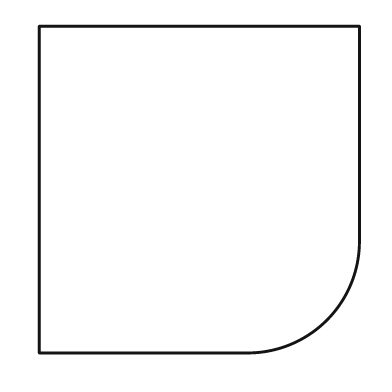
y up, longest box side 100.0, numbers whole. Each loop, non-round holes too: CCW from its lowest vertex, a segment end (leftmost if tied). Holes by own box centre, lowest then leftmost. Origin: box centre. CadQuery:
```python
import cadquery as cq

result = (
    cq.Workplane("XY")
    .moveTo(-49.0, -50.0)
    .lineTo(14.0, -50.0)
    .threePointArc((39.0, -40.0), (49.0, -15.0))
    .lineTo(49.0, 50.0)
    .lineTo(-49.0, 50.0)
    .close()
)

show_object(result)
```